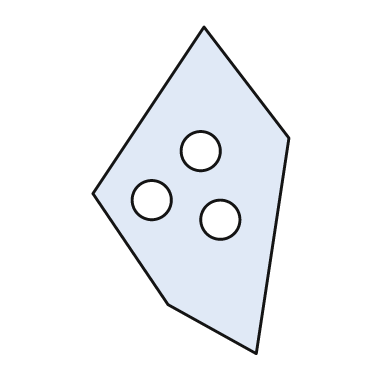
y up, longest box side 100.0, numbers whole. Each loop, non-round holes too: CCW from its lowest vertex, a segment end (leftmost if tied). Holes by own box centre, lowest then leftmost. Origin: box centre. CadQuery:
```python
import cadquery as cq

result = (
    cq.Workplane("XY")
    .moveTo(20.0, -50.0)
    .lineTo(30.0, 16.0)
    .lineTo(4.0, 50.0)
    .lineTo(-30.0, -1.0)
    .lineTo(-7.0, -35.0)
    .close()
    .moveTo(9.0, -9.0)
    .circle(6.0)
    .moveTo(-12.0, -3.0)
    .circle(6.0)
    .moveTo(3.0, 12.0)
    .circle(6.0)
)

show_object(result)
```